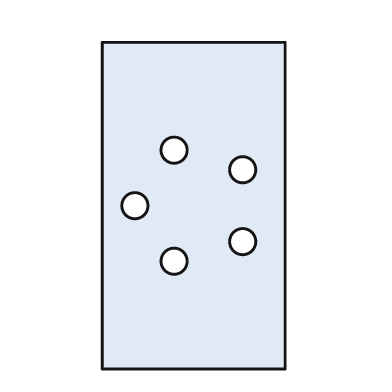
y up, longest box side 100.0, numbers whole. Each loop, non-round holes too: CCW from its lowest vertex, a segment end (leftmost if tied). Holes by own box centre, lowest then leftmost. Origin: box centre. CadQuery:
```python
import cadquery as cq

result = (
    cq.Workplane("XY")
    .moveTo(-28.0, -50.0)
    .lineTo(28.0, -50.0)
    .lineTo(28.0, 50.0)
    .lineTo(-28.0, 50.0)
    .close()
    .moveTo(-6.0, -17.0)
    .circle(4.0)
    .moveTo(15.0, -11.0)
    .circle(4.0)
    .moveTo(-18.0, 0.0)
    .circle(4.0)
    .moveTo(15.0, 11.0)
    .circle(4.0)
    .moveTo(-6.0, 17.0)
    .circle(4.0)
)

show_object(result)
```